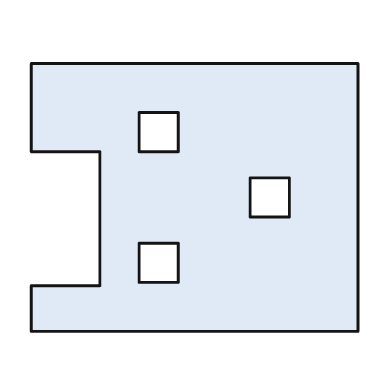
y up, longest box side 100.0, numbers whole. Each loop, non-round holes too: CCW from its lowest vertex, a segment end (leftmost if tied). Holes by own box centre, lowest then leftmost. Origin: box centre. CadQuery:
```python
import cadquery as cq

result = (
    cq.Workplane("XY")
    .moveTo(-50.0, -41.0)
    .lineTo(50.0, -41.0)
    .lineTo(50.0, 41.0)
    .lineTo(-50.0, 41.0)
    .lineTo(-50.0, 14.0)
    .lineTo(-29.0, 14.0)
    .lineTo(-29.0, -27.0)
    .lineTo(-50.0, -27.0)
    .close()
    .moveTo(-17.0, -26.0)
    .lineTo(-5.0, -26.0)
    .lineTo(-5.0, -14.0)
    .lineTo(-17.0, -14.0)
    .close()
    .moveTo(17.0, -6.0)
    .lineTo(29.0, -6.0)
    .lineTo(29.0, 6.0)
    .lineTo(17.0, 6.0)
    .close()
    .moveTo(-17.0, 14.0)
    .lineTo(-5.0, 14.0)
    .lineTo(-5.0, 26.0)
    .lineTo(-17.0, 26.0)
    .close()
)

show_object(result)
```